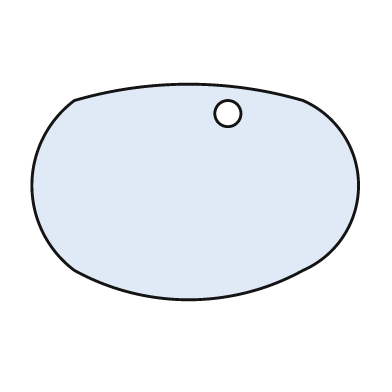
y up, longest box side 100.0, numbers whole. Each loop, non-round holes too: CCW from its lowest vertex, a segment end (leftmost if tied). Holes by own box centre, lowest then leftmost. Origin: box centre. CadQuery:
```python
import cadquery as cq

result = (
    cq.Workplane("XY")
    .moveTo(-37.0, -24.0)
    .threePointArc((-2.0, -33.0), (33.0, -24.0))
    .threePointArc((50.0, 2.0), (33.0, 28.0))
    .threePointArc((-2.0, 33.0), (-37.0, 28.0))
    .threePointArc((-50.0, 2.0), (-37.0, -24.0))
    .close()
    .moveTo(10.0, 24.0)
    .circle(4.0)
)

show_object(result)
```